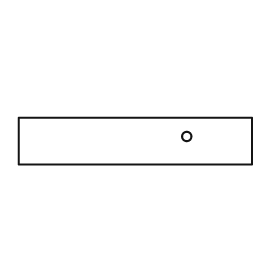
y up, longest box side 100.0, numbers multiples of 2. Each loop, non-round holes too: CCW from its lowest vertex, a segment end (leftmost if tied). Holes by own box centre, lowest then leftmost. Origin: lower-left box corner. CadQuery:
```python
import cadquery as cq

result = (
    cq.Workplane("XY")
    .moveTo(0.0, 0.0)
    .lineTo(100.0, 0.0)
    .lineTo(100.0, 20.0)
    .lineTo(0.0, 20.0)
    .close()
    .moveTo(72.0, 12.0)
    .circle(2.0)
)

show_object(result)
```